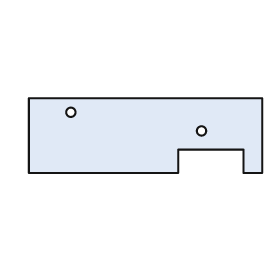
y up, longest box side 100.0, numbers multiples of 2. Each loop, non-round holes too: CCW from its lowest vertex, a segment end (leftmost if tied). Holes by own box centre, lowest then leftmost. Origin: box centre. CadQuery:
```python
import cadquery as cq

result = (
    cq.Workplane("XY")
    .moveTo(-50.0, -16.0)
    .lineTo(14.0, -16.0)
    .lineTo(14.0, -6.0)
    .lineTo(42.0, -6.0)
    .lineTo(42.0, -16.0)
    .lineTo(50.0, -16.0)
    .lineTo(50.0, 16.0)
    .lineTo(-50.0, 16.0)
    .close()
    .moveTo(24.0, 2.0)
    .circle(2.0)
    .moveTo(-32.0, 10.0)
    .circle(2.0)
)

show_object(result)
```